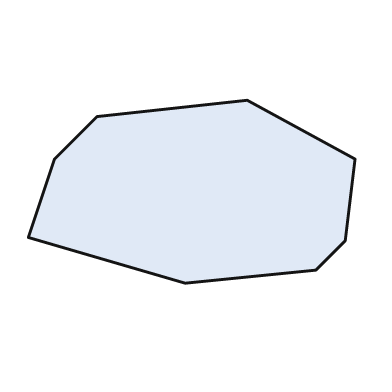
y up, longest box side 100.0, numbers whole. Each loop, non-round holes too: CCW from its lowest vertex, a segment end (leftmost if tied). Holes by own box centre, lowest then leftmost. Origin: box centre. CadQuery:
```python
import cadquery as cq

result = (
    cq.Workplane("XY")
    .moveTo(-2.0, -28.0)
    .lineTo(38.0, -24.0)
    .lineTo(47.0, -15.0)
    .lineTo(50.0, 10.0)
    .lineTo(17.0, 28.0)
    .lineTo(-29.0, 23.0)
    .lineTo(-42.0, 10.0)
    .lineTo(-50.0, -14.0)
    .close()
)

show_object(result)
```